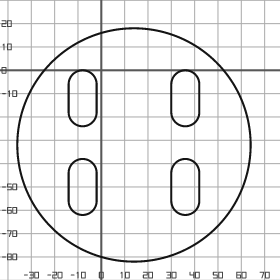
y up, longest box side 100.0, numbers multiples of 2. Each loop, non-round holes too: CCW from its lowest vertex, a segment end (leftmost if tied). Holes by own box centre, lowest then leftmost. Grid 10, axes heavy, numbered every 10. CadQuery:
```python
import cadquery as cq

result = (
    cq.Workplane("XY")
    .moveTo(14.0, -32.0)
    .circle(50.0)
    .moveTo(-14.0, -56.0)
    .threePointArc((-8.0, -62.0), (-2.0, -56.0))
    .lineTo(-2.0, -44.0)
    .threePointArc((-8.0, -38.0), (-14.0, -44.0))
    .close()
    .moveTo(30.0, -56.0)
    .threePointArc((36.0, -62.0), (42.0, -56.0))
    .lineTo(42.0, -44.0)
    .threePointArc((36.0, -38.0), (30.0, -44.0))
    .close()
    .moveTo(-14.0, -18.0)
    .threePointArc((-8.0, -24.0), (-2.0, -18.0))
    .lineTo(-2.0, -6.0)
    .threePointArc((-8.0, 0.0), (-14.0, -6.0))
    .close()
    .moveTo(30.0, -18.0)
    .threePointArc((36.0, -24.0), (42.0, -18.0))
    .lineTo(42.0, -6.0)
    .threePointArc((36.0, 0.0), (30.0, -6.0))
    .close()
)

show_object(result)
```